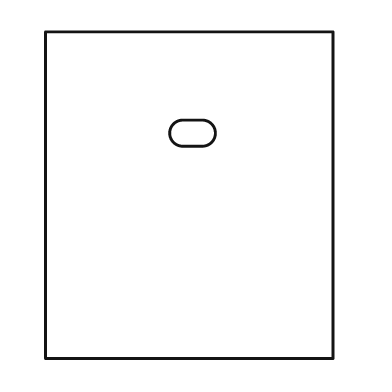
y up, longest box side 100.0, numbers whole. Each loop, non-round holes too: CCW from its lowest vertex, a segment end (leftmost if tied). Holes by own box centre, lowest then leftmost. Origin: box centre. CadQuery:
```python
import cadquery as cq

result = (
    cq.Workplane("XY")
    .moveTo(-44.0, -50.0)
    .lineTo(44.0, -50.0)
    .lineTo(44.0, 50.0)
    .lineTo(-44.0, 50.0)
    .close()
    .moveTo(-2.0, 15.0)
    .lineTo(4.0, 15.0)
    .threePointArc((8.0, 19.0), (4.0, 23.0))
    .lineTo(-2.0, 23.0)
    .threePointArc((-6.0, 19.0), (-2.0, 15.0))
    .close()
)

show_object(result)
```